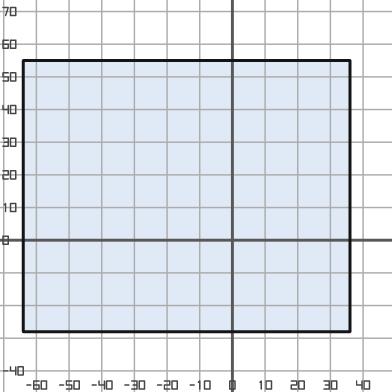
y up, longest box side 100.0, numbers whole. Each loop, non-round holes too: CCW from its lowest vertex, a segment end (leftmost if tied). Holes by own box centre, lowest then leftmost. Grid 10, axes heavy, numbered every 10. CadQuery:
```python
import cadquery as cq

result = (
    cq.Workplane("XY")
    .moveTo(-64.0, -28.0)
    .lineTo(36.0, -28.0)
    .lineTo(36.0, 55.0)
    .lineTo(-64.0, 55.0)
    .close()
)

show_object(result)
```